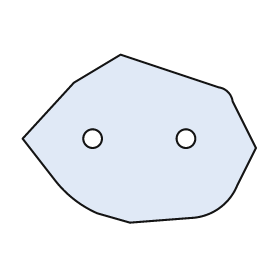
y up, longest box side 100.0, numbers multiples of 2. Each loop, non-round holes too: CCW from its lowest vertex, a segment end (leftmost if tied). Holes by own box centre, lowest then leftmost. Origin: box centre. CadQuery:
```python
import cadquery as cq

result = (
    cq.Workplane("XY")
    .moveTo(-4.0, -36.0)
    .lineTo(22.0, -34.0)
    .threePointArc((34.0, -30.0), (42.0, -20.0))
    .lineTo(50.0, -4.0)
    .lineTo(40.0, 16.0)
    .threePointArc((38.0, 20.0), (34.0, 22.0))
    .lineTo(-8.0, 36.0)
    .lineTo(-28.0, 24.0)
    .lineTo(-50.0, 0.0)
    .lineTo(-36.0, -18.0)
    .threePointArc((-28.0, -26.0), (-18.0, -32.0))
    .close()
    .moveTo(-20.0, 0.0)
    .circle(4.0)
    .moveTo(20.0, 0.0)
    .circle(4.0)
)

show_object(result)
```